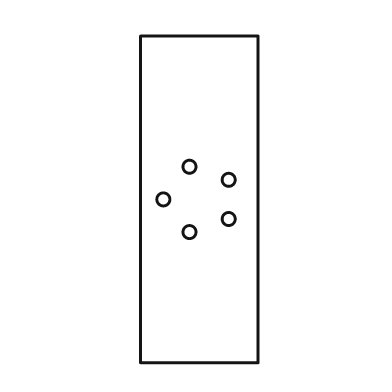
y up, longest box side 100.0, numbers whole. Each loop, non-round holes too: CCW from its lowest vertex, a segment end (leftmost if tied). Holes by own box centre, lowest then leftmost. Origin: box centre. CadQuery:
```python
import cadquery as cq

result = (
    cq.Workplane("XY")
    .moveTo(-18.0, -50.0)
    .lineTo(18.0, -50.0)
    .lineTo(18.0, 50.0)
    .lineTo(-18.0, 50.0)
    .close()
    .moveTo(-3.0, -10.0)
    .circle(2.0)
    .moveTo(9.0, -6.0)
    .circle(2.0)
    .moveTo(-11.0, 0.0)
    .circle(2.0)
    .moveTo(9.0, 6.0)
    .circle(2.0)
    .moveTo(-3.0, 10.0)
    .circle(2.0)
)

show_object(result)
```